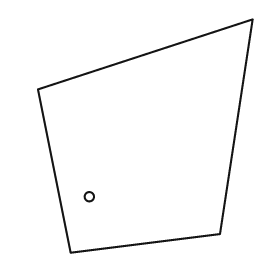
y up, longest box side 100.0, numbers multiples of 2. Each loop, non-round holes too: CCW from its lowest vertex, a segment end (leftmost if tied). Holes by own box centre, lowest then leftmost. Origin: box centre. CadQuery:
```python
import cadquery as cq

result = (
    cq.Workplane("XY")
    .moveTo(-32.0, -50.0)
    .lineTo(32.0, -42.0)
    .lineTo(46.0, 50.0)
    .lineTo(-46.0, 20.0)
    .close()
    .moveTo(-24.0, -26.0)
    .circle(2.0)
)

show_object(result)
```